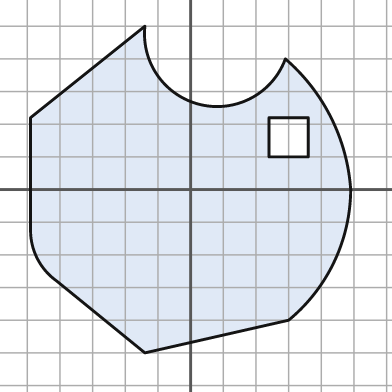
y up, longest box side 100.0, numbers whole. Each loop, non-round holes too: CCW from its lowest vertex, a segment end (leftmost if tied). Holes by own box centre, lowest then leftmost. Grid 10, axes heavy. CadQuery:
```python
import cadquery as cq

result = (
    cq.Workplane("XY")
    .moveTo(-14.0, -50.0)
    .lineTo(30.0, -40.0)
    .threePointArc((44.0, -22.0), (49.0, 0.0))
    .threePointArc((43.0, 22.0), (29.0, 40.0))
    .threePointArc((3.0, 26.0), (-14.0, 50.0))
    .lineTo(-49.0, 22.0)
    .lineTo(-49.0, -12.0)
    .threePointArc((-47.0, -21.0), (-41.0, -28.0))
    .close()
    .moveTo(24.0, 10.0)
    .lineTo(36.0, 10.0)
    .lineTo(36.0, 22.0)
    .lineTo(24.0, 22.0)
    .close()
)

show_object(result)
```